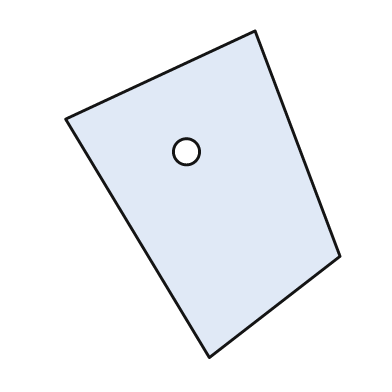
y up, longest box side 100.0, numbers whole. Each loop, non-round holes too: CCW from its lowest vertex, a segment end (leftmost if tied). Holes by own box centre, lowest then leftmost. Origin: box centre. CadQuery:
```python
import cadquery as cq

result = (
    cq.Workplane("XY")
    .moveTo(2.0, -50.0)
    .lineTo(42.0, -19.0)
    .lineTo(16.0, 50.0)
    .lineTo(-42.0, 23.0)
    .close()
    .moveTo(-5.0, 13.0)
    .circle(4.0)
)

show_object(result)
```